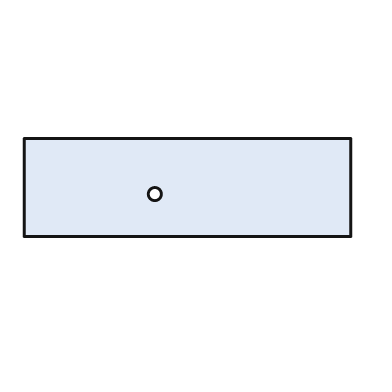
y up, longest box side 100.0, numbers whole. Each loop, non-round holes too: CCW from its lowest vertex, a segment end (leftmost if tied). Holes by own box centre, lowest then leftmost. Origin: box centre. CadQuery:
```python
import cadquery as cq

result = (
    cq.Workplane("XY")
    .moveTo(-50.0, -15.0)
    .lineTo(50.0, -15.0)
    .lineTo(50.0, 15.0)
    .lineTo(-50.0, 15.0)
    .close()
    .moveTo(-10.0, -2.0)
    .circle(2.0)
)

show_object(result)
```